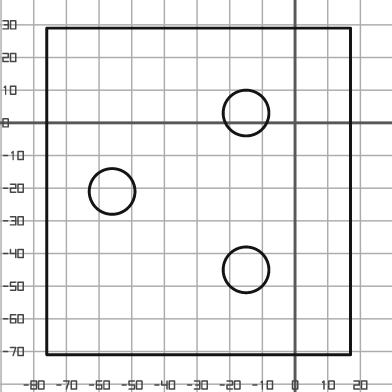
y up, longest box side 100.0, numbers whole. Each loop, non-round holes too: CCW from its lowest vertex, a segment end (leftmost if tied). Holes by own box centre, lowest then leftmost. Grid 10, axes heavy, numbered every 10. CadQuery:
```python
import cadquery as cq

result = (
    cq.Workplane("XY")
    .moveTo(-76.0, -71.0)
    .lineTo(17.0, -71.0)
    .lineTo(17.0, 29.0)
    .lineTo(-76.0, 29.0)
    .close()
    .moveTo(-15.0, -45.0)
    .circle(7.0)
    .moveTo(-56.0, -21.0)
    .circle(7.0)
    .moveTo(-15.0, 3.0)
    .circle(7.0)
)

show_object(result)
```